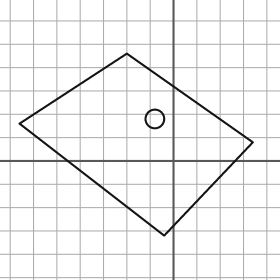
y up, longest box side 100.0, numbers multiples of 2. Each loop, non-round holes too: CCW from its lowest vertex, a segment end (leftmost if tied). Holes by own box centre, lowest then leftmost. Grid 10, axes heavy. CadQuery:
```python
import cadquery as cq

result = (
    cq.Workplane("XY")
    .moveTo(-4.0, -32.0)
    .lineTo(34.0, 8.0)
    .lineTo(-20.0, 46.0)
    .lineTo(-66.0, 16.0)
    .close()
    .moveTo(-8.0, 18.0)
    .circle(4.0)
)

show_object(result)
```